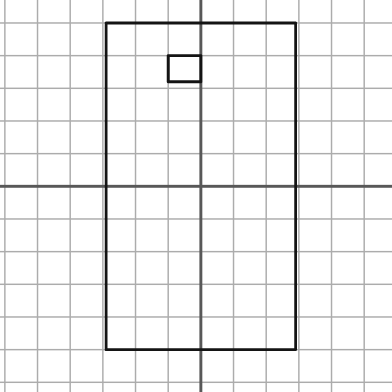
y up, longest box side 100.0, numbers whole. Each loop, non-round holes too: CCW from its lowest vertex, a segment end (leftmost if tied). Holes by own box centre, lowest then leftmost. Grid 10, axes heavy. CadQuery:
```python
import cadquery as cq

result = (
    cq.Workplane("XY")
    .moveTo(-29.0, -50.0)
    .lineTo(29.0, -50.0)
    .lineTo(29.0, 50.0)
    .lineTo(-29.0, 50.0)
    .close()
    .moveTo(-10.0, 32.0)
    .lineTo(0.0, 32.0)
    .lineTo(0.0, 40.0)
    .lineTo(-10.0, 40.0)
    .close()
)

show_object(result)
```